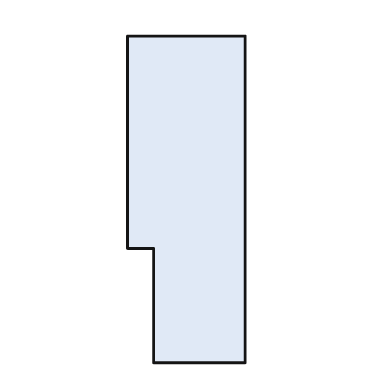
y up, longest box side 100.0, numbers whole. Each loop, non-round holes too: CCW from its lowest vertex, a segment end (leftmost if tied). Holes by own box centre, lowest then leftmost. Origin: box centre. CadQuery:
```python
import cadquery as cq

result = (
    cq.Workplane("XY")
    .moveTo(-10.0, -50.0)
    .lineTo(18.0, -50.0)
    .lineTo(18.0, 50.0)
    .lineTo(-18.0, 50.0)
    .lineTo(-18.0, -15.0)
    .lineTo(-10.0, -15.0)
    .close()
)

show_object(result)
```